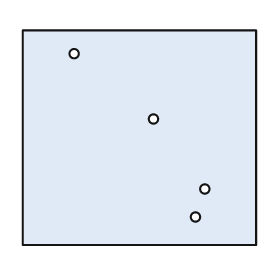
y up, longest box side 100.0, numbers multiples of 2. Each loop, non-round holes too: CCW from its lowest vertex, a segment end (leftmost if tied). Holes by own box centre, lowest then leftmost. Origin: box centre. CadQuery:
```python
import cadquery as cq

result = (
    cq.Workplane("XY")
    .moveTo(-50.0, -46.0)
    .lineTo(50.0, -46.0)
    .lineTo(50.0, 46.0)
    .lineTo(-50.0, 46.0)
    .close()
    .moveTo(24.0, -34.0)
    .circle(2.0)
    .moveTo(28.0, -22.0)
    .circle(2.0)
    .moveTo(6.0, 8.0)
    .circle(2.0)
    .moveTo(-28.0, 36.0)
    .circle(2.0)
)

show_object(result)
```